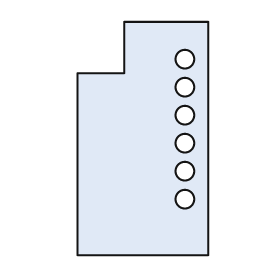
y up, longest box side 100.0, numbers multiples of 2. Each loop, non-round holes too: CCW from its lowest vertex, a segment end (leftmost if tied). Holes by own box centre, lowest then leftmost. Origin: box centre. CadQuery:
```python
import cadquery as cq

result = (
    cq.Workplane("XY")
    .moveTo(-28.0, -50.0)
    .lineTo(28.0, -50.0)
    .lineTo(28.0, 50.0)
    .lineTo(-8.0, 50.0)
    .lineTo(-8.0, 28.0)
    .lineTo(-28.0, 28.0)
    .close()
    .moveTo(18.0, -26.0)
    .circle(4.0)
    .moveTo(18.0, -14.0)
    .circle(4.0)
    .moveTo(18.0, -2.0)
    .circle(4.0)
    .moveTo(18.0, 10.0)
    .circle(4.0)
    .moveTo(18.0, 22.0)
    .circle(4.0)
    .moveTo(18.0, 34.0)
    .circle(4.0)
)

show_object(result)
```